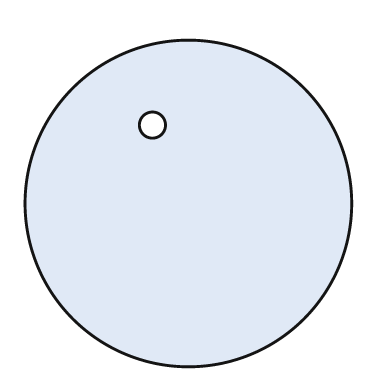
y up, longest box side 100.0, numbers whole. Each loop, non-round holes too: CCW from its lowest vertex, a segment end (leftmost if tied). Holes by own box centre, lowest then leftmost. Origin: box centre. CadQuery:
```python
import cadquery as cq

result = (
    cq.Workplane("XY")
    .moveTo(0.0, 0.0)
    .circle(50.0)
    .moveTo(-11.0, 24.0)
    .circle(4.0)
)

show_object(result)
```